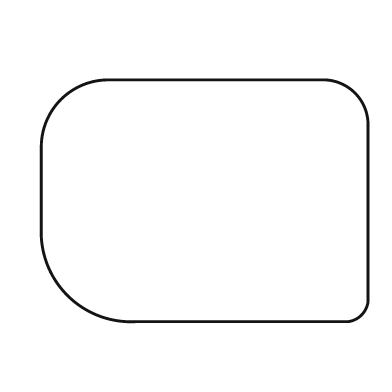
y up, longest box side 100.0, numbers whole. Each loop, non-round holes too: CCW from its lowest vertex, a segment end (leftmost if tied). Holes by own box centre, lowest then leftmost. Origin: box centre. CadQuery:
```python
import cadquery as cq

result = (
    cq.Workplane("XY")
    .moveTo(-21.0, -37.0)
    .lineTo(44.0, -37.0)
    .threePointArc((48.0, -35.0), (50.0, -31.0))
    .lineTo(50.0, 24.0)
    .threePointArc((46.0, 33.0), (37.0, 37.0))
    .lineTo(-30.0, 37.0)
    .threePointArc((-44.0, 31.0), (-50.0, 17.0))
    .lineTo(-50.0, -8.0)
    .threePointArc((-42.0, -29.0), (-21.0, -37.0))
    .close()
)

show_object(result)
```